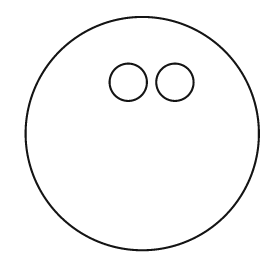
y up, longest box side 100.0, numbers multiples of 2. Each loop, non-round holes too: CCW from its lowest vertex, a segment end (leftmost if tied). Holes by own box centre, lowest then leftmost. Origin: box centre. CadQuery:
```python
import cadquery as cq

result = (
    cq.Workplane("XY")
    .moveTo(0.0, 0.0)
    .circle(50.0)
    .moveTo(-6.0, 22.0)
    .circle(8.0)
    .moveTo(14.0, 22.0)
    .circle(8.0)
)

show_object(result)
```